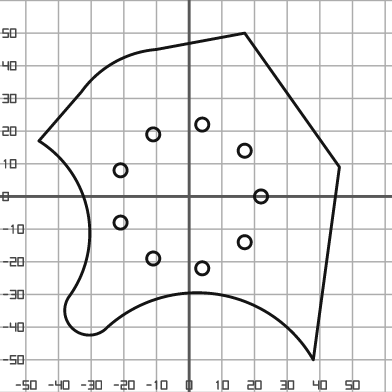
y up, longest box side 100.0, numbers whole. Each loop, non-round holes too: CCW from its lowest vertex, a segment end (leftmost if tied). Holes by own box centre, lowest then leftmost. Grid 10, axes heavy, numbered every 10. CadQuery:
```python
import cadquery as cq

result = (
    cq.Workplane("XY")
    .moveTo(38.0, -50.0)
    .lineTo(46.0, 9.0)
    .lineTo(17.0, 50.0)
    .lineTo(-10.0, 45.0)
    .threePointArc((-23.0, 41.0), (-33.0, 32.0))
    .lineTo(-46.0, 17.0)
    .threePointArc((-31.0, -5.0), (-37.0, -31.0))
    .threePointArc((-35.0, -41.0), (-25.0, -40.0))
    .threePointArc((9.0, -30.0), (38.0, -50.0))
    .close()
    .moveTo(4.0, -22.0)
    .circle(2.0)
    .moveTo(-11.0, -19.0)
    .circle(2.0)
    .moveTo(17.0, -14.0)
    .circle(2.0)
    .moveTo(-21.0, -8.0)
    .circle(2.0)
    .moveTo(22.0, 0.0)
    .circle(2.0)
    .moveTo(-21.0, 8.0)
    .circle(2.0)
    .moveTo(17.0, 14.0)
    .circle(2.0)
    .moveTo(-11.0, 19.0)
    .circle(2.0)
    .moveTo(4.0, 22.0)
    .circle(2.0)
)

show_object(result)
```